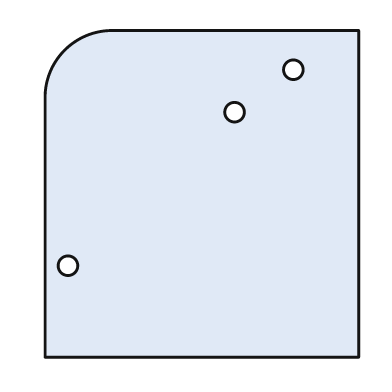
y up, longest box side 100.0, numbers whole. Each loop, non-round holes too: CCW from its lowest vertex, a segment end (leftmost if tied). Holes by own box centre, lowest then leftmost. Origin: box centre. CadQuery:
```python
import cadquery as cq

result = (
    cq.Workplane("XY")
    .moveTo(-48.0, -50.0)
    .lineTo(48.0, -50.0)
    .lineTo(48.0, 50.0)
    .lineTo(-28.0, 50.0)
    .threePointArc((-42.0, 44.0), (-48.0, 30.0))
    .close()
    .moveTo(-41.0, -22.0)
    .circle(3.0)
    .moveTo(10.0, 25.0)
    .circle(3.0)
    .moveTo(28.0, 38.0)
    .circle(3.0)
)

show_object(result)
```